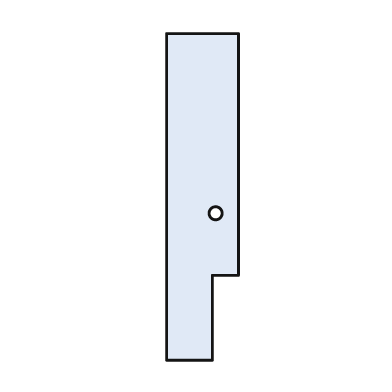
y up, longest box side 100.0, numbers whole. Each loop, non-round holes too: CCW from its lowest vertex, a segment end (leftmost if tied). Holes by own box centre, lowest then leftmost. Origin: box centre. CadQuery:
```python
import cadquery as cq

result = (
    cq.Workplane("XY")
    .moveTo(-11.0, -50.0)
    .lineTo(3.0, -50.0)
    .lineTo(3.0, -24.0)
    .lineTo(11.0, -24.0)
    .lineTo(11.0, 50.0)
    .lineTo(-11.0, 50.0)
    .close()
    .moveTo(4.0, -5.0)
    .circle(2.0)
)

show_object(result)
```